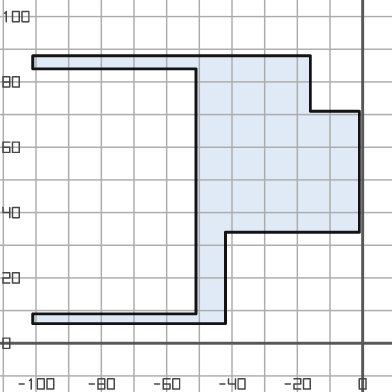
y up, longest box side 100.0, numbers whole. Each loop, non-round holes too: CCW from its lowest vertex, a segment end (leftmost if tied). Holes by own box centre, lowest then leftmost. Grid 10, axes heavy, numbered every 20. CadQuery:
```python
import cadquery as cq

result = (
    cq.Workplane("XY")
    .moveTo(-101.0, 6.0)
    .lineTo(-42.0, 6.0)
    .lineTo(-42.0, 34.0)
    .lineTo(-1.0, 34.0)
    .lineTo(-1.0, 71.0)
    .lineTo(-16.0, 71.0)
    .lineTo(-16.0, 88.0)
    .lineTo(-101.0, 88.0)
    .lineTo(-101.0, 84.0)
    .lineTo(-51.0, 84.0)
    .lineTo(-51.0, 9.0)
    .lineTo(-101.0, 9.0)
    .close()
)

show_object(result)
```